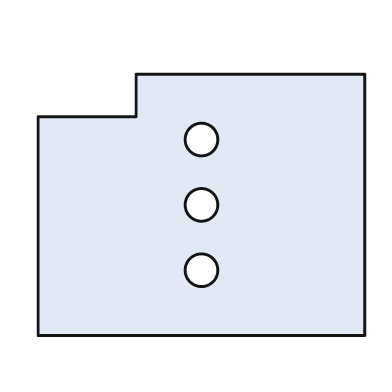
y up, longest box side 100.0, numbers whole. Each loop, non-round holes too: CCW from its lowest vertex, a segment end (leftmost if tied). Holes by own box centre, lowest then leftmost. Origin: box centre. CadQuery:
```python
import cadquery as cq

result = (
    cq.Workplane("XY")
    .moveTo(-50.0, -40.0)
    .lineTo(50.0, -40.0)
    .lineTo(50.0, 40.0)
    .lineTo(-20.0, 40.0)
    .lineTo(-20.0, 27.0)
    .lineTo(-50.0, 27.0)
    .close()
    .moveTo(0.0, -20.0)
    .circle(5.0)
    .moveTo(0.0, 0.0)
    .circle(5.0)
    .moveTo(0.0, 20.0)
    .circle(5.0)
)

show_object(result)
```